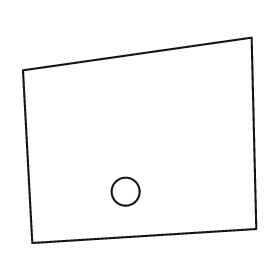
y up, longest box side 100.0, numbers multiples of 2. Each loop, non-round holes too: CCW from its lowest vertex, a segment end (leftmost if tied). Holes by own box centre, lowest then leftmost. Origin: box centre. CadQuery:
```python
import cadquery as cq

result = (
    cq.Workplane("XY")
    .moveTo(-46.0, -44.0)
    .lineTo(50.0, -38.0)
    .lineTo(48.0, 44.0)
    .lineTo(-50.0, 30.0)
    .close()
    .moveTo(-6.0, -22.0)
    .circle(6.0)
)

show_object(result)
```